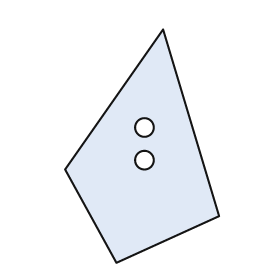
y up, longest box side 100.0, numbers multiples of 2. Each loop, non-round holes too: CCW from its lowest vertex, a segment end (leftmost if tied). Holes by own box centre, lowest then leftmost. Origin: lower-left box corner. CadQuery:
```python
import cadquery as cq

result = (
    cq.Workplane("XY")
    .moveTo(22.0, 0.0)
    .lineTo(66.0, 20.0)
    .lineTo(42.0, 100.0)
    .lineTo(0.0, 40.0)
    .close()
    .moveTo(34.0, 44.0)
    .circle(4.0)
    .moveTo(34.0, 58.0)
    .circle(4.0)
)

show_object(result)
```